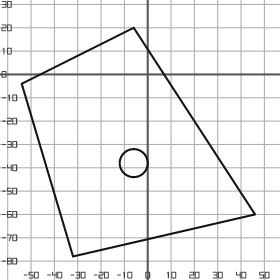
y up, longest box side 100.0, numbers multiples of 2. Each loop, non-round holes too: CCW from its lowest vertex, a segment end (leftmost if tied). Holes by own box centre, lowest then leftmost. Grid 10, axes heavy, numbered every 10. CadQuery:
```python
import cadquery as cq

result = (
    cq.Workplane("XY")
    .moveTo(-32.0, -78.0)
    .lineTo(46.0, -60.0)
    .lineTo(-6.0, 20.0)
    .lineTo(-54.0, -4.0)
    .close()
    .moveTo(-6.0, -38.0)
    .circle(6.0)
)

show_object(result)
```